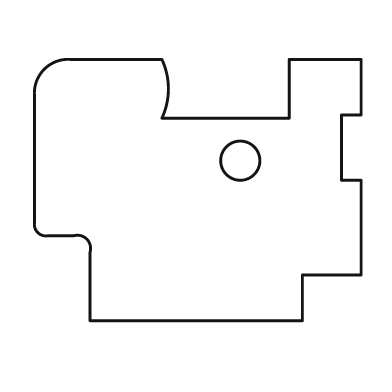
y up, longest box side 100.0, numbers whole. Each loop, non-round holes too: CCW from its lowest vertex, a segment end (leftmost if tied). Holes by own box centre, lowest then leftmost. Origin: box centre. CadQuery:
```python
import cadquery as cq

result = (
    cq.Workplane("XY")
    .moveTo(-33.0, -40.0)
    .lineTo(32.0, -40.0)
    .lineTo(32.0, -26.0)
    .lineTo(50.0, -26.0)
    .lineTo(50.0, 3.0)
    .lineTo(44.0, 3.0)
    .lineTo(44.0, 23.0)
    .lineTo(50.0, 23.0)
    .lineTo(50.0, 40.0)
    .lineTo(28.0, 40.0)
    .lineTo(28.0, 22.0)
    .lineTo(-11.0, 22.0)
    .threePointArc((-9.0, 31.0), (-11.0, 40.0))
    .lineTo(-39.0, 40.0)
    .threePointArc((-47.0, 37.0), (-50.0, 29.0))
    .lineTo(-50.0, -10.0)
    .threePointArc((-49.0, -13.0), (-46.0, -14.0))
    .lineTo(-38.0, -14.0)
    .threePointArc((-34.0, -15.0), (-33.0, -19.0))
    .close()
    .moveTo(13.0, 9.0)
    .circle(6.0)
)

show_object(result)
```